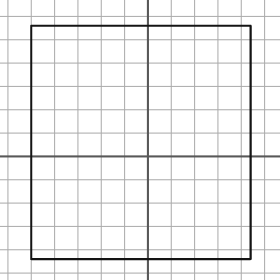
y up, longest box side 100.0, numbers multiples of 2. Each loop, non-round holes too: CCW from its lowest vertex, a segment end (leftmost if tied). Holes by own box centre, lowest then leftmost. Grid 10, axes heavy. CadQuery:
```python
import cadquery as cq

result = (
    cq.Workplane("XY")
    .moveTo(-50.0, -44.0)
    .lineTo(44.0, -44.0)
    .lineTo(44.0, 56.0)
    .lineTo(-50.0, 56.0)
    .close()
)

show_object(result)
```